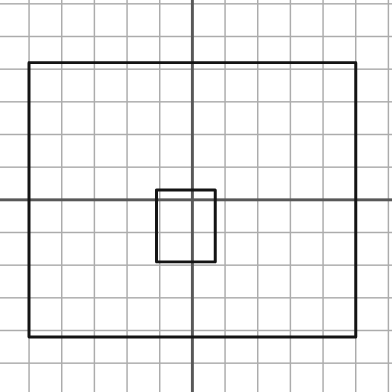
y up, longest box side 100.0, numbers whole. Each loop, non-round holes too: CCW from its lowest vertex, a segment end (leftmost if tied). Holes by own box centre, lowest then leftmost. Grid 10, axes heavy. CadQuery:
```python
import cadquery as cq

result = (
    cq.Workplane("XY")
    .moveTo(-50.0, -42.0)
    .lineTo(50.0, -42.0)
    .lineTo(50.0, 42.0)
    .lineTo(-50.0, 42.0)
    .close()
    .moveTo(-11.0, -19.0)
    .lineTo(7.0, -19.0)
    .lineTo(7.0, 3.0)
    .lineTo(-11.0, 3.0)
    .close()
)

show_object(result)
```